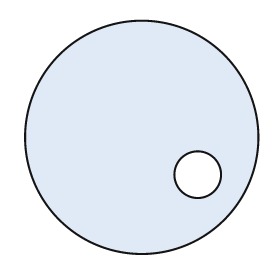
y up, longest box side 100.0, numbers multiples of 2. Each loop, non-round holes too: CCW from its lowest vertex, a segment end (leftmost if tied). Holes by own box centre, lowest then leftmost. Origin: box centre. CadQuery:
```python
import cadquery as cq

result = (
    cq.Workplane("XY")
    .moveTo(0.0, 0.0)
    .circle(50.0)
    .moveTo(24.0, -16.0)
    .circle(10.0)
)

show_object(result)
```